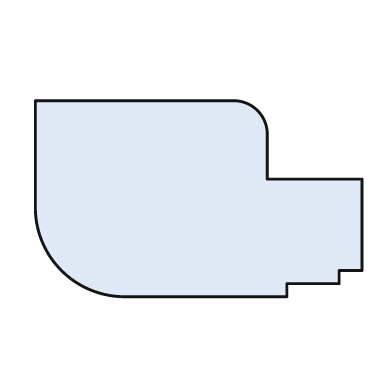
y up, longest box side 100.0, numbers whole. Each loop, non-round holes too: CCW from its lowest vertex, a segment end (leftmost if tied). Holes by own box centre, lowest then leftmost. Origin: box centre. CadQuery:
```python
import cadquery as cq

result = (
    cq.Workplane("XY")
    .moveTo(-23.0, -30.0)
    .lineTo(27.0, -30.0)
    .lineTo(27.0, -26.0)
    .lineTo(43.0, -26.0)
    .lineTo(43.0, -22.0)
    .lineTo(50.0, -22.0)
    .lineTo(50.0, 6.0)
    .lineTo(21.0, 6.0)
    .lineTo(21.0, 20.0)
    .threePointArc((18.0, 27.0), (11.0, 30.0))
    .lineTo(-50.0, 30.0)
    .lineTo(-50.0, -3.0)
    .threePointArc((-42.0, -22.0), (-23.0, -30.0))
    .close()
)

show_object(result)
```